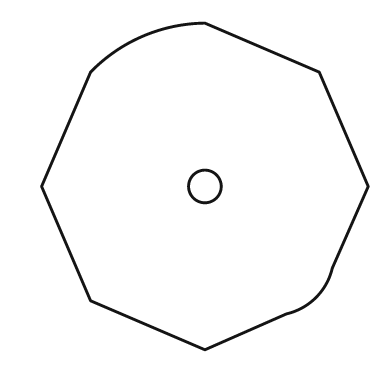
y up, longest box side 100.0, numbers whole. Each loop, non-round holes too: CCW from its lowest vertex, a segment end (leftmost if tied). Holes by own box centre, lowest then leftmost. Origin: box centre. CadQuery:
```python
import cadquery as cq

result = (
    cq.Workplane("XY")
    .moveTo(0.0, -50.0)
    .lineTo(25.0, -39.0)
    .threePointArc((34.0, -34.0), (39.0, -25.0))
    .lineTo(50.0, 0.0)
    .lineTo(35.0, 35.0)
    .lineTo(0.0, 50.0)
    .threePointArc((-19.0, 46.0), (-35.0, 35.0))
    .lineTo(-50.0, 0.0)
    .lineTo(-35.0, -35.0)
    .close()
    .moveTo(0.0, 0.0)
    .circle(5.0)
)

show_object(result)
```